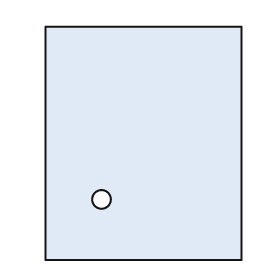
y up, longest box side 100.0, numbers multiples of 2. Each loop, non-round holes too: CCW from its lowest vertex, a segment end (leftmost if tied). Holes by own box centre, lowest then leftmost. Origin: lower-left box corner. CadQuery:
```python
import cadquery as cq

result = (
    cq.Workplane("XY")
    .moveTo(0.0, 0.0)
    .lineTo(84.0, 0.0)
    .lineTo(84.0, 100.0)
    .lineTo(0.0, 100.0)
    .close()
    .moveTo(24.0, 26.0)
    .circle(4.0)
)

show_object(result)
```